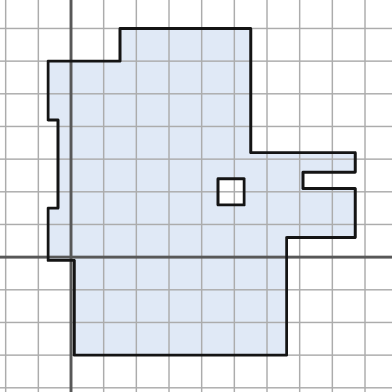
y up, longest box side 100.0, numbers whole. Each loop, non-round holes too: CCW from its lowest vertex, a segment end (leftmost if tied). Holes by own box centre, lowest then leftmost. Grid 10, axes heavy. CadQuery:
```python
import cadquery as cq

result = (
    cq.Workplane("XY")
    .moveTo(1.0, -30.0)
    .lineTo(66.0, -30.0)
    .lineTo(66.0, 6.0)
    .lineTo(87.0, 6.0)
    .lineTo(87.0, 21.0)
    .lineTo(71.0, 21.0)
    .lineTo(71.0, 26.0)
    .lineTo(87.0, 26.0)
    .lineTo(87.0, 32.0)
    .lineTo(55.0, 32.0)
    .lineTo(55.0, 70.0)
    .lineTo(15.0, 70.0)
    .lineTo(15.0, 60.0)
    .lineTo(-7.0, 60.0)
    .lineTo(-7.0, 42.0)
    .lineTo(-4.0, 42.0)
    .lineTo(-4.0, 15.0)
    .lineTo(-7.0, 15.0)
    .lineTo(-7.0, -1.0)
    .lineTo(1.0, -1.0)
    .close()
    .moveTo(45.0, 16.0)
    .lineTo(53.0, 16.0)
    .lineTo(53.0, 24.0)
    .lineTo(45.0, 24.0)
    .close()
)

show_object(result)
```